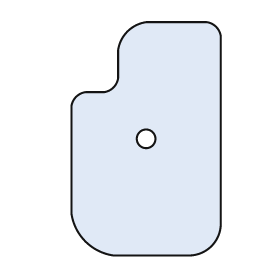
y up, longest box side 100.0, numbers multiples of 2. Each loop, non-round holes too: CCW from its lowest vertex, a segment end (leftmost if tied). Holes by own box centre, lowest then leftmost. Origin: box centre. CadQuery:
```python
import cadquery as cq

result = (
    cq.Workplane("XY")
    .moveTo(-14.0, -50.0)
    .lineTo(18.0, -50.0)
    .threePointArc((28.0, -46.0), (32.0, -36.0))
    .lineTo(32.0, 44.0)
    .threePointArc((30.0, 48.0), (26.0, 50.0))
    .lineTo(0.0, 50.0)
    .threePointArc((-8.0, 46.0), (-12.0, 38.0))
    .lineTo(-12.0, 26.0)
    .threePointArc((-14.0, 22.0), (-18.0, 20.0))
    .lineTo(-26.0, 20.0)
    .threePointArc((-30.0, 18.0), (-32.0, 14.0))
    .lineTo(-32.0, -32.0)
    .threePointArc((-26.0, -44.0), (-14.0, -50.0))
    .close()
    .moveTo(0.0, 0.0)
    .circle(4.0)
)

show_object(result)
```